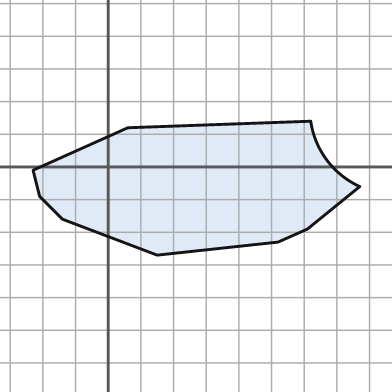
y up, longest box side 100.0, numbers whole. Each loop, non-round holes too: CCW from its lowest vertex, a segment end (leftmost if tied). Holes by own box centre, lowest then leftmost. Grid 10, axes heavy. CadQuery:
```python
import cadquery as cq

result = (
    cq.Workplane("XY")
    .moveTo(15.0, -27.0)
    .lineTo(52.0, -23.0)
    .lineTo(61.0, -19.0)
    .lineTo(77.0, -6.0)
    .threePointArc((67.0, 2.0), (62.0, 14.0))
    .lineTo(6.0, 12.0)
    .lineTo(-23.0, -1.0)
    .lineTo(-21.0, -9.0)
    .lineTo(-14.0, -16.0)
    .close()
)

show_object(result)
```